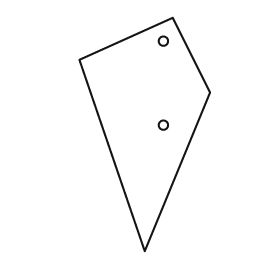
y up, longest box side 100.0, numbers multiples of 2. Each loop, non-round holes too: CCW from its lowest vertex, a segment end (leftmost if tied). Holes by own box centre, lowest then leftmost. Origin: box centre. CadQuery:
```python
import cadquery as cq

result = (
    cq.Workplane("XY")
    .moveTo(0.0, -50.0)
    .lineTo(28.0, 18.0)
    .lineTo(12.0, 50.0)
    .lineTo(-28.0, 32.0)
    .close()
    .moveTo(8.0, 4.0)
    .circle(2.0)
    .moveTo(8.0, 40.0)
    .circle(2.0)
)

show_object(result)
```